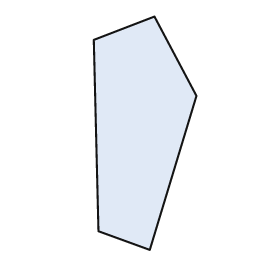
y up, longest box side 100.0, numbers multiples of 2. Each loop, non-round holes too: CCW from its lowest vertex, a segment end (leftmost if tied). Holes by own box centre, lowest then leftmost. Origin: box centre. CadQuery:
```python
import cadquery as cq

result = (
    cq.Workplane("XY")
    .moveTo(2.0, -50.0)
    .lineTo(22.0, 16.0)
    .lineTo(4.0, 50.0)
    .lineTo(-22.0, 40.0)
    .lineTo(-20.0, -42.0)
    .close()
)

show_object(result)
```